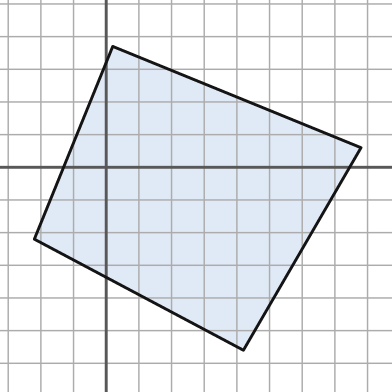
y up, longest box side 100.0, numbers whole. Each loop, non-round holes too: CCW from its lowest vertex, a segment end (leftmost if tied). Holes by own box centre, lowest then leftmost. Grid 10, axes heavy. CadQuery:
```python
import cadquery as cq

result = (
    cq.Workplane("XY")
    .moveTo(42.0, -56.0)
    .lineTo(78.0, 6.0)
    .lineTo(2.0, 37.0)
    .lineTo(-22.0, -22.0)
    .close()
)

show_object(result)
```